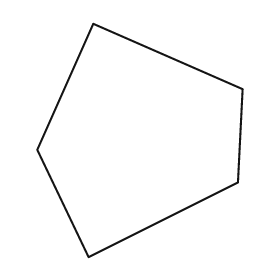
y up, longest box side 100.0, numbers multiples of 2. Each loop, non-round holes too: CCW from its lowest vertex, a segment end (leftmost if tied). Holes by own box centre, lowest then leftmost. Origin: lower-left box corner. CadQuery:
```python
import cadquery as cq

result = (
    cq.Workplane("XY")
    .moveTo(22.0, 0.0)
    .lineTo(86.0, 32.0)
    .lineTo(88.0, 72.0)
    .lineTo(24.0, 100.0)
    .lineTo(0.0, 46.0)
    .close()
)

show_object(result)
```